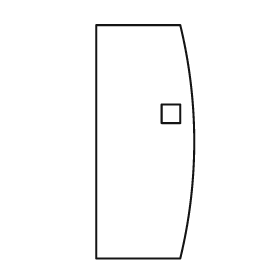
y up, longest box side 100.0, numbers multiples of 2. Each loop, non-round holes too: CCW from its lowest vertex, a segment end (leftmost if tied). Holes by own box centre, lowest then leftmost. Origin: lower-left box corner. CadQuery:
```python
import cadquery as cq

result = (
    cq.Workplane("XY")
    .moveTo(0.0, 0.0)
    .lineTo(36.0, 0.0)
    .threePointArc((42.0, 50.0), (36.0, 100.0))
    .lineTo(0.0, 100.0)
    .close()
    .moveTo(28.0, 58.0)
    .lineTo(36.0, 58.0)
    .lineTo(36.0, 66.0)
    .lineTo(28.0, 66.0)
    .close()
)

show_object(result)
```